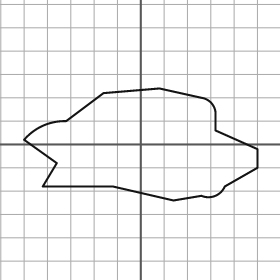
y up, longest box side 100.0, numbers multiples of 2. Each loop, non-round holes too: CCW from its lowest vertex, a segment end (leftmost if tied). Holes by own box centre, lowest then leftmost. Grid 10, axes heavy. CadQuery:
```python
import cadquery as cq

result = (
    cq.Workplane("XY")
    .moveTo(14.0, -24.0)
    .lineTo(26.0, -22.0)
    .threePointArc((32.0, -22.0), (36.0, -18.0))
    .lineTo(50.0, -10.0)
    .lineTo(50.0, -2.0)
    .lineTo(32.0, 6.0)
    .lineTo(32.0, 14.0)
    .threePointArc((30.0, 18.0), (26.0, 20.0))
    .lineTo(8.0, 24.0)
    .lineTo(-16.0, 22.0)
    .lineTo(-32.0, 10.0)
    .threePointArc((-42.0, 8.0), (-50.0, 2.0))
    .lineTo(-36.0, -8.0)
    .lineTo(-42.0, -18.0)
    .lineTo(-12.0, -18.0)
    .close()
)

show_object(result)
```